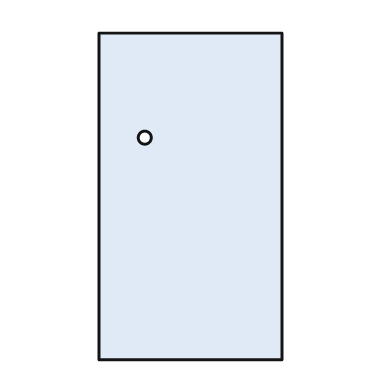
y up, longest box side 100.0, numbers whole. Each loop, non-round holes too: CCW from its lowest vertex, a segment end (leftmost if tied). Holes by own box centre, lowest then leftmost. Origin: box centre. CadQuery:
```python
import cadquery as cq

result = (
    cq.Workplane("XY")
    .moveTo(-28.0, -50.0)
    .lineTo(28.0, -50.0)
    .lineTo(28.0, 50.0)
    .lineTo(-28.0, 50.0)
    .close()
    .moveTo(-14.0, 18.0)
    .circle(2.0)
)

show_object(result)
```